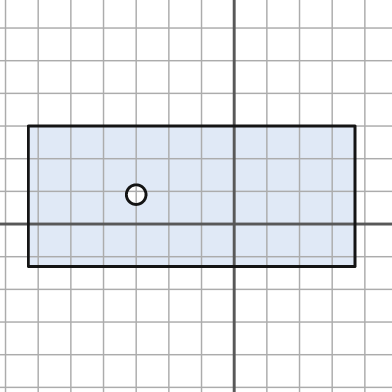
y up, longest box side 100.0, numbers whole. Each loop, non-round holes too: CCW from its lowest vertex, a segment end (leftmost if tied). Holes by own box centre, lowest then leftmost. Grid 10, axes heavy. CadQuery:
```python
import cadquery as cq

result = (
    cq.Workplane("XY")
    .moveTo(-63.0, -13.0)
    .lineTo(37.0, -13.0)
    .lineTo(37.0, 30.0)
    .lineTo(-63.0, 30.0)
    .close()
    .moveTo(-30.0, 9.0)
    .circle(3.0)
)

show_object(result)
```